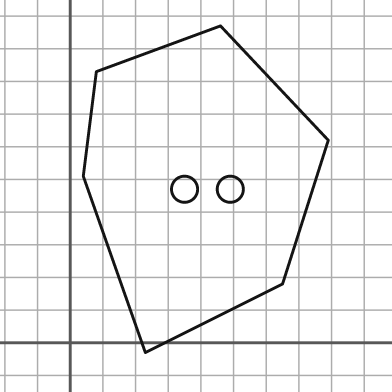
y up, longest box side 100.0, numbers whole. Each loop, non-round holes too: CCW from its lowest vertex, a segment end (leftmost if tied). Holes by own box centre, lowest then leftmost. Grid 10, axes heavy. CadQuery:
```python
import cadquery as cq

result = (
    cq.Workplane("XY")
    .moveTo(23.0, -3.0)
    .lineTo(65.0, 18.0)
    .lineTo(79.0, 62.0)
    .lineTo(46.0, 97.0)
    .lineTo(8.0, 83.0)
    .lineTo(4.0, 51.0)
    .close()
    .moveTo(35.0, 47.0)
    .circle(4.0)
    .moveTo(49.0, 47.0)
    .circle(4.0)
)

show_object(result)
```